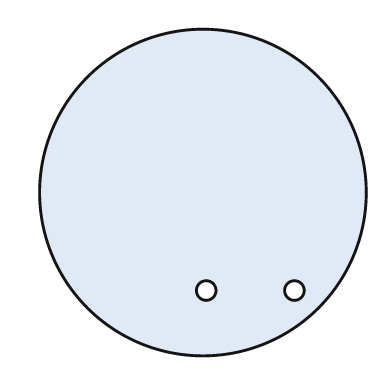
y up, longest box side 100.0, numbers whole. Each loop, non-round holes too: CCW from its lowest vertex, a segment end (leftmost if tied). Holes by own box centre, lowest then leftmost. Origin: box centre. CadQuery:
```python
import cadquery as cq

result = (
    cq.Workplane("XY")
    .moveTo(0.0, 0.0)
    .circle(50.0)
    .moveTo(1.0, -30.0)
    .circle(3.0)
    .moveTo(28.0, -30.0)
    .circle(3.0)
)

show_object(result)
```